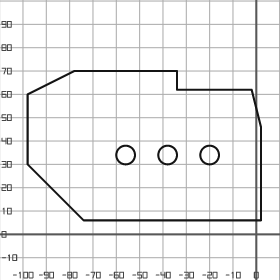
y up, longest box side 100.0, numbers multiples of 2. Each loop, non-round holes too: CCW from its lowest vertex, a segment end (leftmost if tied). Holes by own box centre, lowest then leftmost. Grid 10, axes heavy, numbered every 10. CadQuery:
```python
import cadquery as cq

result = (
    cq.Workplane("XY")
    .moveTo(-74.0, 6.0)
    .lineTo(2.0, 6.0)
    .lineTo(2.0, 46.0)
    .lineTo(-2.0, 62.0)
    .lineTo(-34.0, 62.0)
    .lineTo(-34.0, 70.0)
    .lineTo(-78.0, 70.0)
    .lineTo(-98.0, 60.0)
    .lineTo(-98.0, 30.0)
    .close()
    .moveTo(-56.0, 34.0)
    .circle(4.0)
    .moveTo(-38.0, 34.0)
    .circle(4.0)
    .moveTo(-20.0, 34.0)
    .circle(4.0)
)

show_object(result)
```